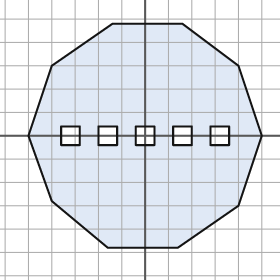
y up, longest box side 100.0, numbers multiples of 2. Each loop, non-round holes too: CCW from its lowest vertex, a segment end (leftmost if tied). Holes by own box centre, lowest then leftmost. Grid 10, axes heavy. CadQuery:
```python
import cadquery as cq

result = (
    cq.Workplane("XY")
    .moveTo(-16.0, -48.0)
    .lineTo(14.0, -48.0)
    .lineTo(40.0, -30.0)
    .lineTo(50.0, 0.0)
    .lineTo(40.0, 30.0)
    .lineTo(16.0, 48.0)
    .lineTo(-14.0, 48.0)
    .lineTo(-40.0, 30.0)
    .lineTo(-50.0, 0.0)
    .lineTo(-40.0, -28.0)
    .close()
    .moveTo(-36.0, -4.0)
    .lineTo(-28.0, -4.0)
    .lineTo(-28.0, 4.0)
    .lineTo(-36.0, 4.0)
    .close()
    .moveTo(-20.0, -4.0)
    .lineTo(-12.0, -4.0)
    .lineTo(-12.0, 4.0)
    .lineTo(-20.0, 4.0)
    .close()
    .moveTo(-4.0, -4.0)
    .lineTo(4.0, -4.0)
    .lineTo(4.0, 4.0)
    .lineTo(-4.0, 4.0)
    .close()
    .moveTo(12.0, -4.0)
    .lineTo(20.0, -4.0)
    .lineTo(20.0, 4.0)
    .lineTo(12.0, 4.0)
    .close()
    .moveTo(28.0, -4.0)
    .lineTo(36.0, -4.0)
    .lineTo(36.0, 4.0)
    .lineTo(28.0, 4.0)
    .close()
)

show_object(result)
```